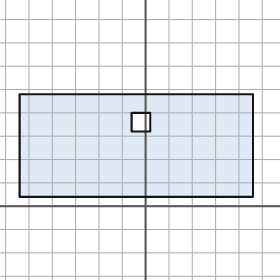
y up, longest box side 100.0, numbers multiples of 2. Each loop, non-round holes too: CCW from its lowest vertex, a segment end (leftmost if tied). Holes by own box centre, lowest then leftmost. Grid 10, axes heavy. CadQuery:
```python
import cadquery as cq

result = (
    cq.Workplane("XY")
    .moveTo(-54.0, 4.0)
    .lineTo(46.0, 4.0)
    .lineTo(46.0, 48.0)
    .lineTo(-54.0, 48.0)
    .close()
    .moveTo(-6.0, 32.0)
    .lineTo(2.0, 32.0)
    .lineTo(2.0, 40.0)
    .lineTo(-6.0, 40.0)
    .close()
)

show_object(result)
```